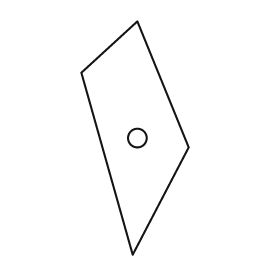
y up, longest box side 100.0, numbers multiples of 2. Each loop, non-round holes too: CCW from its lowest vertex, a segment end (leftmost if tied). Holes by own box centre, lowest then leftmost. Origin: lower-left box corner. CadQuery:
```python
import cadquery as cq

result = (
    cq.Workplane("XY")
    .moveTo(22.0, 0.0)
    .lineTo(46.0, 46.0)
    .lineTo(24.0, 100.0)
    .lineTo(0.0, 78.0)
    .close()
    .moveTo(24.0, 50.0)
    .circle(4.0)
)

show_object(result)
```